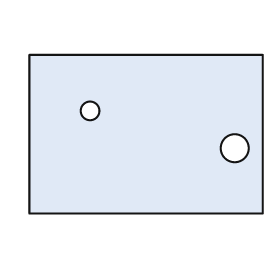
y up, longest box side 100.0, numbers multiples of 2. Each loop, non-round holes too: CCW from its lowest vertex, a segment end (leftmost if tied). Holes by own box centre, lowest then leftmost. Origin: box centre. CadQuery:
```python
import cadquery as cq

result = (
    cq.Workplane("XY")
    .moveTo(-50.0, -34.0)
    .lineTo(50.0, -34.0)
    .lineTo(50.0, 34.0)
    .lineTo(-50.0, 34.0)
    .close()
    .moveTo(38.0, -6.0)
    .circle(6.0)
    .moveTo(-24.0, 10.0)
    .circle(4.0)
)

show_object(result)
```